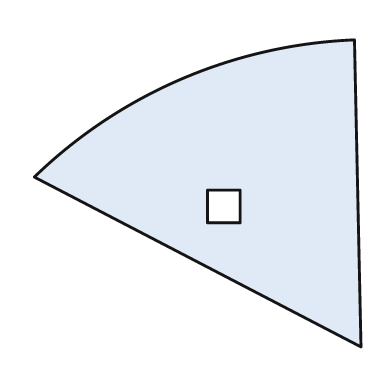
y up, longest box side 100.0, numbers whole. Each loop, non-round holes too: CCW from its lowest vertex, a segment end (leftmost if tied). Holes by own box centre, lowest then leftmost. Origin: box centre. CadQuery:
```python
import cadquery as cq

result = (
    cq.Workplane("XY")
    .moveTo(50.0, -47.0)
    .lineTo(48.0, 47.0)
    .threePointArc((-5.0, 35.0), (-50.0, 5.0))
    .close()
    .moveTo(3.0, -9.0)
    .lineTo(13.0, -9.0)
    .lineTo(13.0, 1.0)
    .lineTo(3.0, 1.0)
    .close()
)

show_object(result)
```